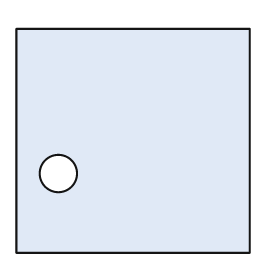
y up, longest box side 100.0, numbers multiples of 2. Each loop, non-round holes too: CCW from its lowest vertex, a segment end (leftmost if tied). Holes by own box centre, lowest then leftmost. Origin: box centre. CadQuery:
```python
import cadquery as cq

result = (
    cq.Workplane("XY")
    .moveTo(-50.0, -48.0)
    .lineTo(50.0, -48.0)
    .lineTo(50.0, 48.0)
    .lineTo(-50.0, 48.0)
    .close()
    .moveTo(-32.0, -14.0)
    .circle(8.0)
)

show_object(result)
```